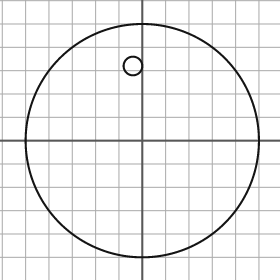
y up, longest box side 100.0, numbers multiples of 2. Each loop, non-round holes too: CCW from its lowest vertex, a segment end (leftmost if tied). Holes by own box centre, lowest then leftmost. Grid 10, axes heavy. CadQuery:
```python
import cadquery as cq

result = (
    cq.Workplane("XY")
    .moveTo(0.0, 0.0)
    .circle(50.0)
    .moveTo(-4.0, 32.0)
    .circle(4.0)
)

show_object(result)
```